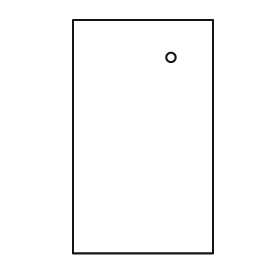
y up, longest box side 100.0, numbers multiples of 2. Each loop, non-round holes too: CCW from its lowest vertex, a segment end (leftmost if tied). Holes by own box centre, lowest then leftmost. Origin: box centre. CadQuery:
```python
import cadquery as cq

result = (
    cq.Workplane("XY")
    .moveTo(-30.0, -50.0)
    .lineTo(30.0, -50.0)
    .lineTo(30.0, 50.0)
    .lineTo(-30.0, 50.0)
    .close()
    .moveTo(12.0, 34.0)
    .circle(2.0)
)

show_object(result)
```